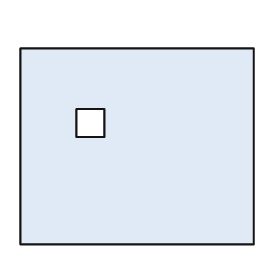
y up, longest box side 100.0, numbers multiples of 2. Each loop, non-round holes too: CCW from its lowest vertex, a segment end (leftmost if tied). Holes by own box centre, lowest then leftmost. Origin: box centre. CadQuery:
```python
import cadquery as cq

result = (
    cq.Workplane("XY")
    .moveTo(-50.0, -42.0)
    .lineTo(50.0, -42.0)
    .lineTo(50.0, 42.0)
    .lineTo(-50.0, 42.0)
    .close()
    .moveTo(-26.0, 4.0)
    .lineTo(-14.0, 4.0)
    .lineTo(-14.0, 16.0)
    .lineTo(-26.0, 16.0)
    .close()
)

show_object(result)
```